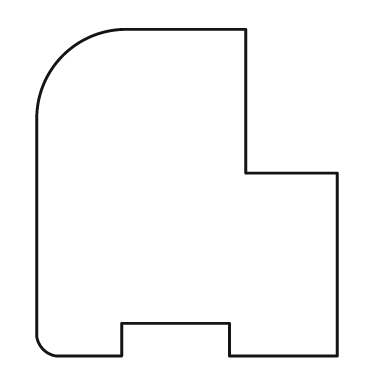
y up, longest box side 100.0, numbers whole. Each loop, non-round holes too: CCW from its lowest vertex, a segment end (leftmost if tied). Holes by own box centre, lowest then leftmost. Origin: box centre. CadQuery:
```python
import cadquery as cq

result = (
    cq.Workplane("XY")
    .moveTo(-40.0, -50.0)
    .lineTo(-20.0, -50.0)
    .lineTo(-20.0, -40.0)
    .lineTo(13.0, -40.0)
    .lineTo(13.0, -50.0)
    .lineTo(46.0, -50.0)
    .lineTo(46.0, 6.0)
    .lineTo(18.0, 6.0)
    .lineTo(18.0, 50.0)
    .lineTo(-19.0, 50.0)
    .threePointArc((-38.0, 42.0), (-46.0, 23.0))
    .lineTo(-46.0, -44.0)
    .threePointArc((-44.0, -48.0), (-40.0, -50.0))
    .close()
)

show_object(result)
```